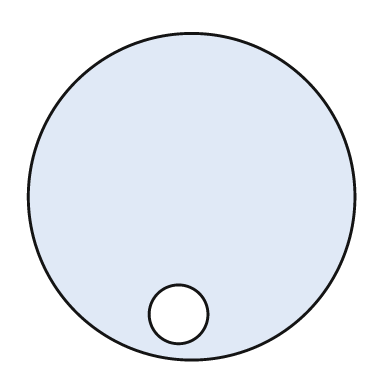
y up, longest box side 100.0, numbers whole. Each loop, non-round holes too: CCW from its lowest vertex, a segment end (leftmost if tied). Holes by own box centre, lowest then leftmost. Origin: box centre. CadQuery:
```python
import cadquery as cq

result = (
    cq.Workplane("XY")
    .moveTo(0.0, 0.0)
    .circle(50.0)
    .moveTo(-4.0, -36.0)
    .circle(9.0)
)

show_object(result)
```